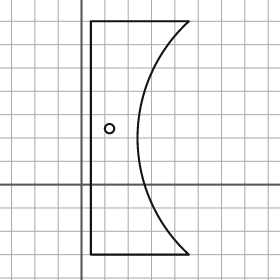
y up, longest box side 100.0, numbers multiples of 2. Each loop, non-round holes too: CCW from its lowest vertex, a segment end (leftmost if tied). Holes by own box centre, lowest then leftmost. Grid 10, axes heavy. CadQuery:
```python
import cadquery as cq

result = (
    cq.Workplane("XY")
    .moveTo(4.0, -30.0)
    .lineTo(46.0, -30.0)
    .threePointArc((24.0, 20.0), (46.0, 70.0))
    .lineTo(4.0, 70.0)
    .close()
    .moveTo(12.0, 24.0)
    .circle(2.0)
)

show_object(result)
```